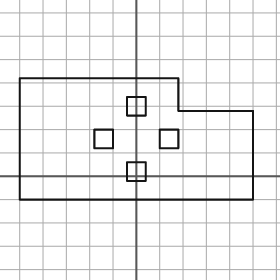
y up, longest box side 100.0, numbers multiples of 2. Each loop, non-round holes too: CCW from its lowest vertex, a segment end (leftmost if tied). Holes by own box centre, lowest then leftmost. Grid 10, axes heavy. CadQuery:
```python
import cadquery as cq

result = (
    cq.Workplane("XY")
    .moveTo(-50.0, -10.0)
    .lineTo(50.0, -10.0)
    .lineTo(50.0, 28.0)
    .lineTo(18.0, 28.0)
    .lineTo(18.0, 42.0)
    .lineTo(-50.0, 42.0)
    .close()
    .moveTo(-4.0, -2.0)
    .lineTo(4.0, -2.0)
    .lineTo(4.0, 6.0)
    .lineTo(-4.0, 6.0)
    .close()
    .moveTo(-18.0, 12.0)
    .lineTo(-10.0, 12.0)
    .lineTo(-10.0, 20.0)
    .lineTo(-18.0, 20.0)
    .close()
    .moveTo(10.0, 12.0)
    .lineTo(18.0, 12.0)
    .lineTo(18.0, 20.0)
    .lineTo(10.0, 20.0)
    .close()
    .moveTo(-4.0, 26.0)
    .lineTo(4.0, 26.0)
    .lineTo(4.0, 34.0)
    .lineTo(-4.0, 34.0)
    .close()
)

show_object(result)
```